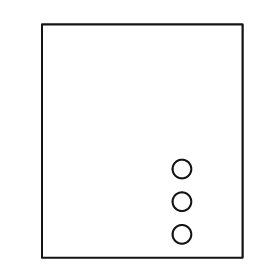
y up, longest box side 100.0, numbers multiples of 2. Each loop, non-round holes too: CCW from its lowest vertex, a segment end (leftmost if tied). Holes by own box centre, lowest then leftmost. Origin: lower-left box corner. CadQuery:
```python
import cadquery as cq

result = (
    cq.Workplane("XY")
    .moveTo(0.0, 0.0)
    .lineTo(86.0, 0.0)
    .lineTo(86.0, 100.0)
    .lineTo(0.0, 100.0)
    .close()
    .moveTo(60.0, 10.0)
    .circle(4.0)
    .moveTo(60.0, 24.0)
    .circle(4.0)
    .moveTo(60.0, 38.0)
    .circle(4.0)
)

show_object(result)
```